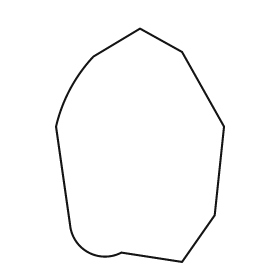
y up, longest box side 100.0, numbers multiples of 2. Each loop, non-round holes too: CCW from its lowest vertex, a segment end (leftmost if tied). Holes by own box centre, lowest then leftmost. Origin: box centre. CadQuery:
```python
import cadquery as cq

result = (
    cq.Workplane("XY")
    .moveTo(18.0, -50.0)
    .lineTo(32.0, -30.0)
    .lineTo(36.0, 8.0)
    .lineTo(18.0, 40.0)
    .lineTo(0.0, 50.0)
    .lineTo(-20.0, 38.0)
    .threePointArc((-30.0, 24.0), (-36.0, 8.0))
    .lineTo(-30.0, -34.0)
    .threePointArc((-22.0, -46.0), (-8.0, -46.0))
    .close()
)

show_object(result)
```